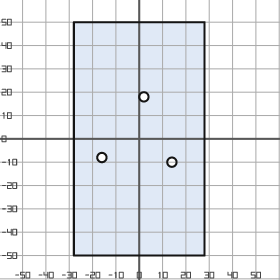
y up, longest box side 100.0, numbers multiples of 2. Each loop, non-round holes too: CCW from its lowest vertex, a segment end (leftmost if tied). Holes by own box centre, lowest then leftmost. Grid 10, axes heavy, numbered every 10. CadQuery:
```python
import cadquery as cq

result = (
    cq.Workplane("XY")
    .moveTo(-28.0, -50.0)
    .lineTo(28.0, -50.0)
    .lineTo(28.0, 50.0)
    .lineTo(-28.0, 50.0)
    .close()
    .moveTo(14.0, -10.0)
    .circle(2.0)
    .moveTo(-16.0, -8.0)
    .circle(2.0)
    .moveTo(2.0, 18.0)
    .circle(2.0)
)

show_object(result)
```